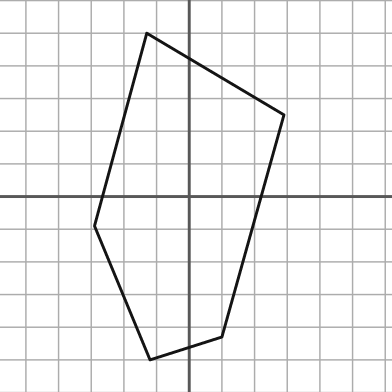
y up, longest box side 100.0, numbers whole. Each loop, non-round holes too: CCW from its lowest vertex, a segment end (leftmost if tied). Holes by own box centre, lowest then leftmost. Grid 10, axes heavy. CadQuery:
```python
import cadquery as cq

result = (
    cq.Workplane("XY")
    .moveTo(-12.0, -50.0)
    .lineTo(10.0, -43.0)
    .lineTo(29.0, 25.0)
    .lineTo(-13.0, 50.0)
    .lineTo(-29.0, -9.0)
    .close()
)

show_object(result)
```